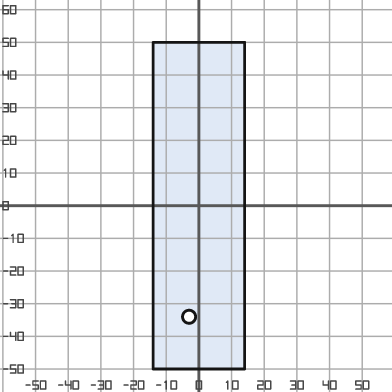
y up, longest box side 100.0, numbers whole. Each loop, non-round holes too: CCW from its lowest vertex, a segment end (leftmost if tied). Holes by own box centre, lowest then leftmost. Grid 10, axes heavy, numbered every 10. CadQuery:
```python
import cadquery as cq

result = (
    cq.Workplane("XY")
    .moveTo(-14.0, -50.0)
    .lineTo(14.0, -50.0)
    .lineTo(14.0, 50.0)
    .lineTo(-14.0, 50.0)
    .close()
    .moveTo(-3.0, -34.0)
    .circle(2.0)
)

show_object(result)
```